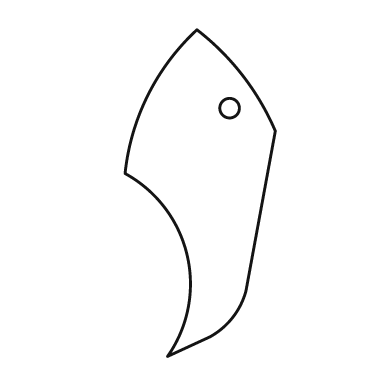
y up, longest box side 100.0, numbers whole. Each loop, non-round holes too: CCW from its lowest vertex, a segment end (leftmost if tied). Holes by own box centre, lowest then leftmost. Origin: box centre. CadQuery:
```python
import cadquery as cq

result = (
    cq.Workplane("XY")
    .moveTo(-10.0, -50.0)
    .lineTo(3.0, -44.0)
    .threePointArc((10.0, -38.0), (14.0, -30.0))
    .lineTo(23.0, 19.0)
    .threePointArc((13.0, 36.0), (-1.0, 50.0))
    .threePointArc((-16.0, 30.0), (-23.0, 6.0))
    .threePointArc((-4.0, -19.0), (-10.0, -50.0))
    .close()
    .moveTo(9.0, 26.0)
    .circle(3.0)
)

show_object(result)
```